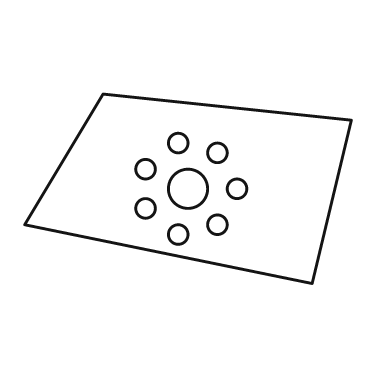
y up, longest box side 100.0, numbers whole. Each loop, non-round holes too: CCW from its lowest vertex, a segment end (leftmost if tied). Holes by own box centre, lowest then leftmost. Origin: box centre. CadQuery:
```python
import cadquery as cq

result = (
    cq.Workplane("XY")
    .moveTo(38.0, -29.0)
    .lineTo(50.0, 21.0)
    .lineTo(-26.0, 29.0)
    .lineTo(-50.0, -11.0)
    .close()
    .moveTo(-3.0, -14.0)
    .circle(3.0)
    .moveTo(9.0, -11.0)
    .circle(3.0)
    .moveTo(-13.0, -6.0)
    .circle(3.0)
    .moveTo(0.0, 0.0)
    .circle(6.0)
    .moveTo(15.0, 0.0)
    .circle(3.0)
    .moveTo(-13.0, 6.0)
    .circle(3.0)
    .moveTo(9.0, 11.0)
    .circle(3.0)
    .moveTo(-3.0, 14.0)
    .circle(3.0)
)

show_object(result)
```